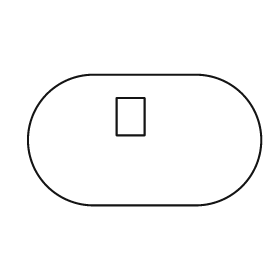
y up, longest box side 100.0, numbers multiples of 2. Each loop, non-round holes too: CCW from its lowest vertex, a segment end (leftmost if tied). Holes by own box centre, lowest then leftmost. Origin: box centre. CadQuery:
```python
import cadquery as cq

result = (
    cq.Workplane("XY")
    .moveTo(-22.0, -28.0)
    .lineTo(22.0, -28.0)
    .threePointArc((50.0, 0.0), (22.0, 28.0))
    .lineTo(-22.0, 28.0)
    .threePointArc((-50.0, 0.0), (-22.0, -28.0))
    .close()
    .moveTo(-12.0, 2.0)
    .lineTo(0.0, 2.0)
    .lineTo(0.0, 18.0)
    .lineTo(-12.0, 18.0)
    .close()
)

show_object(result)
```